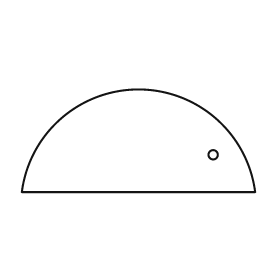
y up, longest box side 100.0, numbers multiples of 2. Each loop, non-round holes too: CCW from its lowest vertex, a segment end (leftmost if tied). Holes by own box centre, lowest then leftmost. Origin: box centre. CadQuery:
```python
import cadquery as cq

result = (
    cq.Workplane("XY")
    .moveTo(-50.0, -22.0)
    .lineTo(50.0, -22.0)
    .threePointArc((0.0, 22.0), (-50.0, -22.0))
    .close()
    .moveTo(32.0, -6.0)
    .circle(2.0)
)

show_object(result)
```